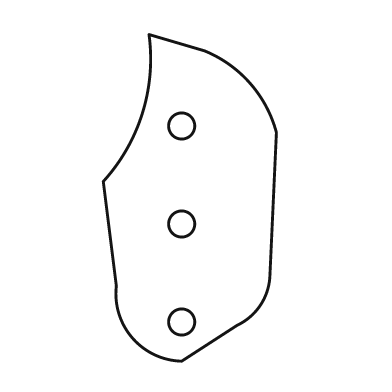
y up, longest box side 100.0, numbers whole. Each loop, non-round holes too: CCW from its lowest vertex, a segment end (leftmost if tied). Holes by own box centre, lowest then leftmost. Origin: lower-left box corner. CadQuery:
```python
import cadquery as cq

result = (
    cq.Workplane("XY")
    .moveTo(24.0, 0.0)
    .lineTo(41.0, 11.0)
    .threePointArc((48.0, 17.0), (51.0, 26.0))
    .lineTo(53.0, 70.0)
    .threePointArc((45.0, 85.0), (31.0, 95.0))
    .lineTo(14.0, 100.0)
    .threePointArc((12.0, 76.0), (0.0, 55.0))
    .lineTo(4.0, 23.0)
    .threePointArc((9.0, 7.0), (24.0, 0.0))
    .close()
    .moveTo(24.0, 12.0)
    .circle(4.0)
    .moveTo(24.0, 42.0)
    .circle(4.0)
    .moveTo(24.0, 72.0)
    .circle(4.0)
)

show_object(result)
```